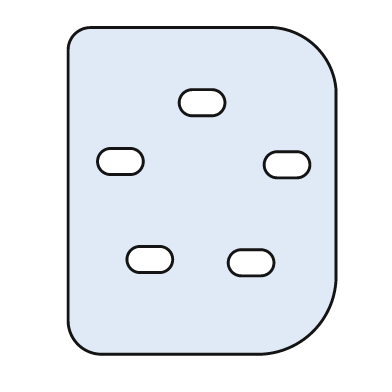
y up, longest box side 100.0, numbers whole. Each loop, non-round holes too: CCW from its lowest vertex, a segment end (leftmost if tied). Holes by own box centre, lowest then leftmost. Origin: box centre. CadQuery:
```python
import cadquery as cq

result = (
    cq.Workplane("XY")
    .moveTo(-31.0, -50.0)
    .lineTo(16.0, -50.0)
    .threePointArc((34.0, -43.0), (41.0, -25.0))
    .lineTo(41.0, 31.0)
    .threePointArc((35.0, 44.0), (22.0, 50.0))
    .lineTo(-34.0, 50.0)
    .threePointArc((-39.0, 48.0), (-41.0, 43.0))
    .lineTo(-41.0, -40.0)
    .threePointArc((-38.0, -47.0), (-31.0, -50.0))
    .close()
    .moveTo(12.0, -26.0)
    .lineTo(18.0, -26.0)
    .threePointArc((22.0, -22.0), (18.0, -18.0))
    .lineTo(12.0, -18.0)
    .threePointArc((8.0, -22.0), (12.0, -26.0))
    .close()
    .moveTo(-19.0, -25.0)
    .lineTo(-13.0, -25.0)
    .threePointArc((-9.0, -21.0), (-13.0, -17.0))
    .lineTo(-19.0, -17.0)
    .threePointArc((-23.0, -21.0), (-19.0, -25.0))
    .close()
    .moveTo(23.0, 4.0)
    .lineTo(29.0, 4.0)
    .threePointArc((33.0, 8.0), (29.0, 12.0))
    .lineTo(23.0, 12.0)
    .threePointArc((19.0, 8.0), (23.0, 4.0))
    .close()
    .moveTo(-28.0, 5.0)
    .lineTo(-22.0, 5.0)
    .threePointArc((-18.0, 9.0), (-22.0, 13.0))
    .lineTo(-28.0, 13.0)
    .threePointArc((-32.0, 9.0), (-28.0, 5.0))
    .close()
    .moveTo(-3.0, 23.0)
    .lineTo(3.0, 23.0)
    .threePointArc((7.0, 27.0), (3.0, 31.0))
    .lineTo(-3.0, 31.0)
    .threePointArc((-7.0, 27.0), (-3.0, 23.0))
    .close()
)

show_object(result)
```